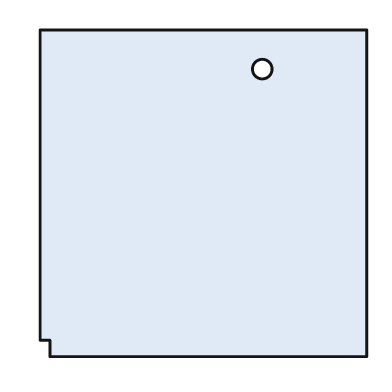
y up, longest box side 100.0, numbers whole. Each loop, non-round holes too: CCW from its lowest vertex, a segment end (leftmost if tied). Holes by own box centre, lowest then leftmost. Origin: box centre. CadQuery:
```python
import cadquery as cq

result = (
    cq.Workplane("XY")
    .moveTo(-47.0, -50.0)
    .lineTo(50.0, -50.0)
    .lineTo(50.0, 50.0)
    .lineTo(-50.0, 50.0)
    .lineTo(-50.0, -45.0)
    .lineTo(-47.0, -45.0)
    .close()
    .moveTo(18.0, 38.0)
    .circle(3.0)
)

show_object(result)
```